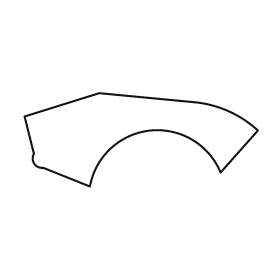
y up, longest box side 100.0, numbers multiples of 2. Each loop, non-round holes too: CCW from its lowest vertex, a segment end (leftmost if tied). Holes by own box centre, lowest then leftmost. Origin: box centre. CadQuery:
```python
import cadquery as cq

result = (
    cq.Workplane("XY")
    .moveTo(-22.0, -20.0)
    .threePointArc((4.0, 4.0), (34.0, -14.0))
    .lineTo(50.0, 4.0)
    .threePointArc((38.0, 12.0), (24.0, 16.0))
    .lineTo(-18.0, 20.0)
    .lineTo(-50.0, 10.0)
    .lineTo(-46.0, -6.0)
    .threePointArc((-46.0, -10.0), (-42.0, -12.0))
    .close()
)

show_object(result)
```